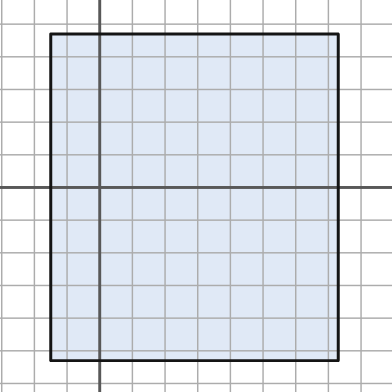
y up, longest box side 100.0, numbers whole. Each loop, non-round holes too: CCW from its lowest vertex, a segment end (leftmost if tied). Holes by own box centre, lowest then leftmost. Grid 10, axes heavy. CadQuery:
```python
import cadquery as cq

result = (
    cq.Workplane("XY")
    .moveTo(-15.0, -53.0)
    .lineTo(73.0, -53.0)
    .lineTo(73.0, 47.0)
    .lineTo(-15.0, 47.0)
    .close()
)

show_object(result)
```